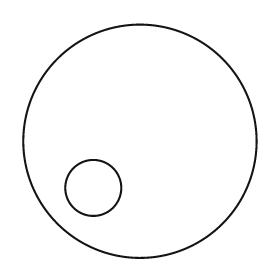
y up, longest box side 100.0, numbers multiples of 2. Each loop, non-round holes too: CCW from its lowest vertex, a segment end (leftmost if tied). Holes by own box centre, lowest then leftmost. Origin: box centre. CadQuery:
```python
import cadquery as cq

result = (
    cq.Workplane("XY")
    .moveTo(0.0, 0.0)
    .circle(50.0)
    .moveTo(-20.0, -20.0)
    .circle(12.0)
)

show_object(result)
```